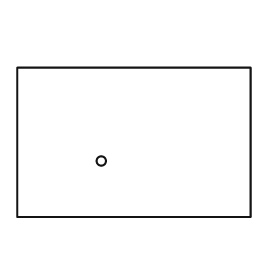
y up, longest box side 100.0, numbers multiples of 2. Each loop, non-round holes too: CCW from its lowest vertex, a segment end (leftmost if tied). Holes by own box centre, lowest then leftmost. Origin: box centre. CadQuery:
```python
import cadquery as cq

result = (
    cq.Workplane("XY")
    .moveTo(-50.0, -32.0)
    .lineTo(50.0, -32.0)
    .lineTo(50.0, 32.0)
    .lineTo(-50.0, 32.0)
    .close()
    .moveTo(-14.0, -8.0)
    .circle(2.0)
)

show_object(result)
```